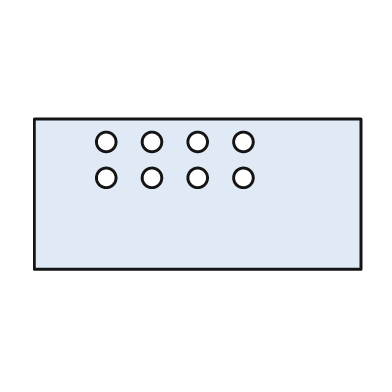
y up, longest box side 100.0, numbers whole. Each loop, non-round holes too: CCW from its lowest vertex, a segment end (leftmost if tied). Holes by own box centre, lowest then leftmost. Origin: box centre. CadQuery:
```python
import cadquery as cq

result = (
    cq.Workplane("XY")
    .moveTo(-50.0, -23.0)
    .lineTo(50.0, -23.0)
    .lineTo(50.0, 23.0)
    .lineTo(-50.0, 23.0)
    .close()
    .moveTo(-28.0, 5.0)
    .circle(3.0)
    .moveTo(-14.0, 5.0)
    .circle(3.0)
    .moveTo(0.0, 5.0)
    .circle(3.0)
    .moveTo(14.0, 5.0)
    .circle(3.0)
    .moveTo(-28.0, 16.0)
    .circle(3.0)
    .moveTo(-14.0, 16.0)
    .circle(3.0)
    .moveTo(0.0, 16.0)
    .circle(3.0)
    .moveTo(14.0, 16.0)
    .circle(3.0)
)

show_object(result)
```